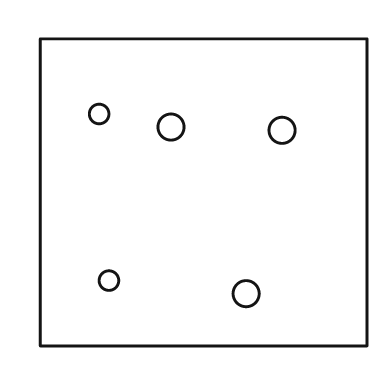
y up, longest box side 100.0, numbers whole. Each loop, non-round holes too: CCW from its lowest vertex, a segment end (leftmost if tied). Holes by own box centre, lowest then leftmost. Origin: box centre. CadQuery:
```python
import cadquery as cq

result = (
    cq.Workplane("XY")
    .moveTo(-50.0, -47.0)
    .lineTo(50.0, -47.0)
    .lineTo(50.0, 47.0)
    .lineTo(-50.0, 47.0)
    .close()
    .moveTo(13.0, -31.0)
    .circle(4.0)
    .moveTo(-29.0, -27.0)
    .circle(3.0)
    .moveTo(24.0, 19.0)
    .circle(4.0)
    .moveTo(-10.0, 20.0)
    .circle(4.0)
    .moveTo(-32.0, 24.0)
    .circle(3.0)
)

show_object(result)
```